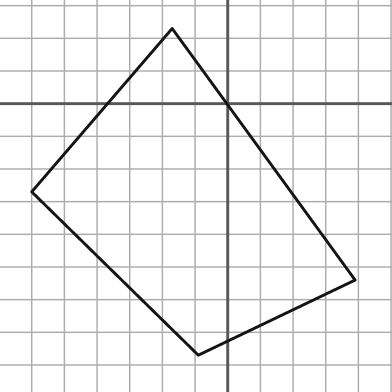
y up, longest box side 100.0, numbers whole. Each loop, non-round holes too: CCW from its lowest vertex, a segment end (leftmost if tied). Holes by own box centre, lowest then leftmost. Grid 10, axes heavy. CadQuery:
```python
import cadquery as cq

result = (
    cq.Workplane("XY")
    .moveTo(-9.0, -77.0)
    .lineTo(39.0, -54.0)
    .lineTo(-17.0, 23.0)
    .lineTo(-60.0, -27.0)
    .close()
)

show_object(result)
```